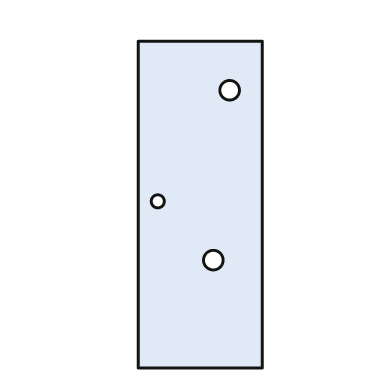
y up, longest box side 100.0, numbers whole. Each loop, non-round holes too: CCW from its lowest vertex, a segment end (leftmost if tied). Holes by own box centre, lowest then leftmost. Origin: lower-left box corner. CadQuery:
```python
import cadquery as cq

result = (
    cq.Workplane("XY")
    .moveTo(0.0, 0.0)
    .lineTo(38.0, 0.0)
    .lineTo(38.0, 100.0)
    .lineTo(0.0, 100.0)
    .close()
    .moveTo(23.0, 33.0)
    .circle(3.0)
    .moveTo(6.0, 51.0)
    .circle(2.0)
    .moveTo(28.0, 85.0)
    .circle(3.0)
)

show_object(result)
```